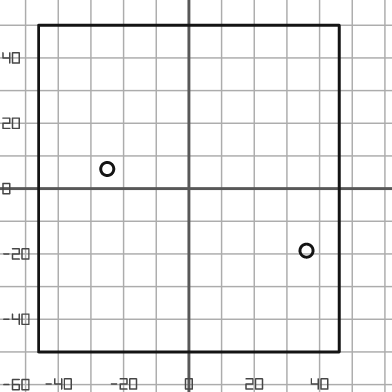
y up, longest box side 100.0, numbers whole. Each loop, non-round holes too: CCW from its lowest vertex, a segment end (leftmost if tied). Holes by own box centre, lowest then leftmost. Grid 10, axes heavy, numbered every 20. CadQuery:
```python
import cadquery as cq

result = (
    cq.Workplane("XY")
    .moveTo(-46.0, -50.0)
    .lineTo(46.0, -50.0)
    .lineTo(46.0, 50.0)
    .lineTo(-46.0, 50.0)
    .close()
    .moveTo(36.0, -19.0)
    .circle(2.0)
    .moveTo(-25.0, 6.0)
    .circle(2.0)
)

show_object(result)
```